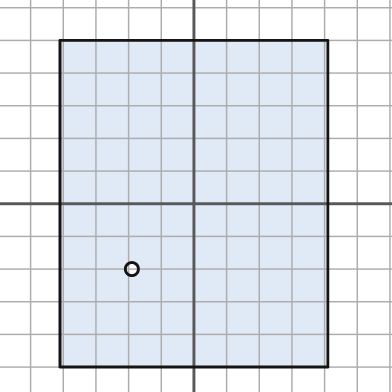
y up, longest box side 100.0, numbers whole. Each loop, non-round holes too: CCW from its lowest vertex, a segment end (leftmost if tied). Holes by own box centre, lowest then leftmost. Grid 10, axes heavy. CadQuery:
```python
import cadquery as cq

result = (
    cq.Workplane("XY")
    .moveTo(-41.0, -50.0)
    .lineTo(41.0, -50.0)
    .lineTo(41.0, 50.0)
    .lineTo(-41.0, 50.0)
    .close()
    .moveTo(-19.0, -20.0)
    .circle(2.0)
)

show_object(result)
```